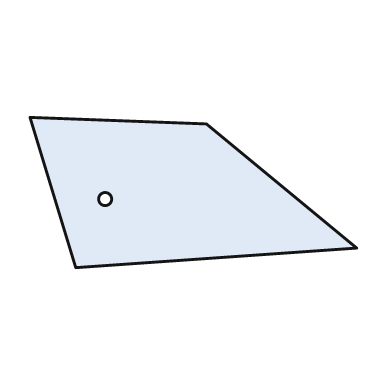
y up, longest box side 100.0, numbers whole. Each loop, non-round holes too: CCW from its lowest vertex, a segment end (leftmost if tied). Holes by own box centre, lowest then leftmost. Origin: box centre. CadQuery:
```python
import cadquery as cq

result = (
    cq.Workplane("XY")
    .moveTo(-36.0, -23.0)
    .lineTo(50.0, -17.0)
    .lineTo(4.0, 21.0)
    .lineTo(-50.0, 23.0)
    .close()
    .moveTo(-27.0, -2.0)
    .circle(2.0)
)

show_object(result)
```